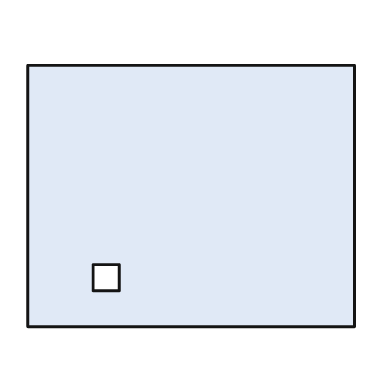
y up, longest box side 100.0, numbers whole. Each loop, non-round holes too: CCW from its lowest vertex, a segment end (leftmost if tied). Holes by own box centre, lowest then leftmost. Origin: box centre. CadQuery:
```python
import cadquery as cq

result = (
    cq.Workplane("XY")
    .moveTo(-50.0, -40.0)
    .lineTo(50.0, -40.0)
    .lineTo(50.0, 40.0)
    .lineTo(-50.0, 40.0)
    .close()
    .moveTo(-30.0, -29.0)
    .lineTo(-22.0, -29.0)
    .lineTo(-22.0, -21.0)
    .lineTo(-30.0, -21.0)
    .close()
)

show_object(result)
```